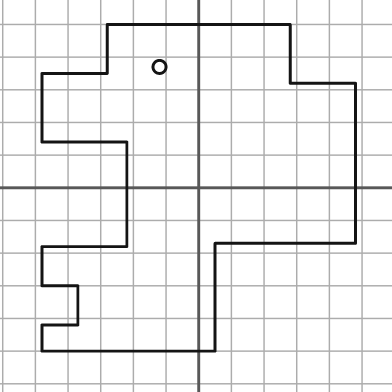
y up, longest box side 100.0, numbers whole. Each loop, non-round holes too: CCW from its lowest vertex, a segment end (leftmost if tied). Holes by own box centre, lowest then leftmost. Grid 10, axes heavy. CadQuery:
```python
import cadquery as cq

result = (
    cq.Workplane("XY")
    .moveTo(-48.0, -50.0)
    .lineTo(5.0, -50.0)
    .lineTo(5.0, -17.0)
    .lineTo(48.0, -17.0)
    .lineTo(48.0, 32.0)
    .lineTo(28.0, 32.0)
    .lineTo(28.0, 50.0)
    .lineTo(-28.0, 50.0)
    .lineTo(-28.0, 35.0)
    .lineTo(-48.0, 35.0)
    .lineTo(-48.0, 14.0)
    .lineTo(-22.0, 14.0)
    .lineTo(-22.0, -18.0)
    .lineTo(-48.0, -18.0)
    .lineTo(-48.0, -30.0)
    .lineTo(-37.0, -30.0)
    .lineTo(-37.0, -42.0)
    .lineTo(-48.0, -42.0)
    .close()
    .moveTo(-12.0, 37.0)
    .circle(2.0)
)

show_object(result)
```